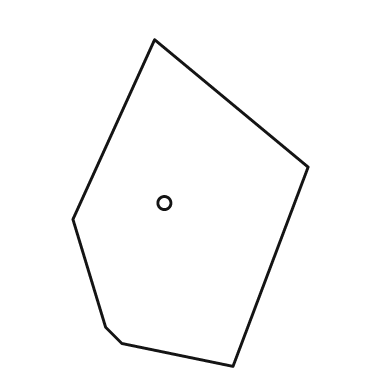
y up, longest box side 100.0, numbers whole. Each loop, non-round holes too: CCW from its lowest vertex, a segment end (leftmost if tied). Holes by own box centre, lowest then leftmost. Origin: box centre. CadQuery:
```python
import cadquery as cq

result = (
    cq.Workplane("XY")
    .moveTo(13.0, -50.0)
    .lineTo(36.0, 11.0)
    .lineTo(-11.0, 50.0)
    .lineTo(-36.0, -5.0)
    .lineTo(-26.0, -38.0)
    .lineTo(-21.0, -43.0)
    .close()
    .moveTo(-8.0, 0.0)
    .circle(2.0)
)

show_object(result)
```